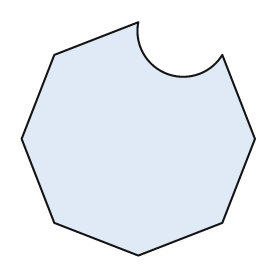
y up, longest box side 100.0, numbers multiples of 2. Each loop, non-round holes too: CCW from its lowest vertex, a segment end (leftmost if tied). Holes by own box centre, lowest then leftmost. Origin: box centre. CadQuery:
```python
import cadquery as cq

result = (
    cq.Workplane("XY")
    .moveTo(0.0, -50.0)
    .lineTo(36.0, -36.0)
    .lineTo(50.0, 0.0)
    .lineTo(36.0, 36.0)
    .threePointArc((12.0, 28.0), (0.0, 50.0))
    .lineTo(-36.0, 36.0)
    .lineTo(-50.0, 0.0)
    .lineTo(-36.0, -36.0)
    .close()
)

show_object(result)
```